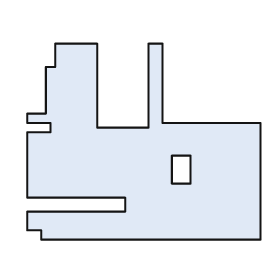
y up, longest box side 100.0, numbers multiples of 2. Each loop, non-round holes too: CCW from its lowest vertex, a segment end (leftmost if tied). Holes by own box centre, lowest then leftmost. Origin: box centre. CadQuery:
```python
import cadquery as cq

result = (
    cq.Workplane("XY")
    .moveTo(-44.0, -42.0)
    .lineTo(50.0, -42.0)
    .lineTo(50.0, 8.0)
    .lineTo(8.0, 8.0)
    .lineTo(8.0, 42.0)
    .lineTo(2.0, 42.0)
    .lineTo(2.0, 6.0)
    .lineTo(-20.0, 6.0)
    .lineTo(-20.0, 42.0)
    .lineTo(-38.0, 42.0)
    .lineTo(-38.0, 32.0)
    .lineTo(-42.0, 32.0)
    .lineTo(-42.0, 12.0)
    .lineTo(-50.0, 12.0)
    .lineTo(-50.0, 8.0)
    .lineTo(-40.0, 8.0)
    .lineTo(-40.0, 4.0)
    .lineTo(-50.0, 4.0)
    .lineTo(-50.0, -24.0)
    .lineTo(-8.0, -24.0)
    .lineTo(-8.0, -30.0)
    .lineTo(-50.0, -30.0)
    .lineTo(-50.0, -38.0)
    .lineTo(-44.0, -38.0)
    .close()
    .moveTo(12.0, -18.0)
    .lineTo(20.0, -18.0)
    .lineTo(20.0, -6.0)
    .lineTo(12.0, -6.0)
    .close()
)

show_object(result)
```